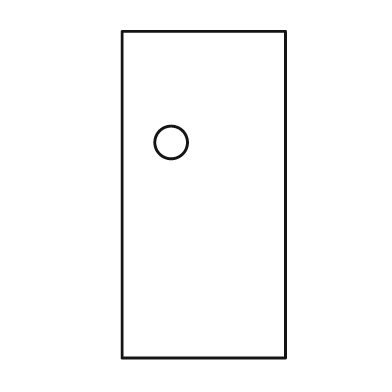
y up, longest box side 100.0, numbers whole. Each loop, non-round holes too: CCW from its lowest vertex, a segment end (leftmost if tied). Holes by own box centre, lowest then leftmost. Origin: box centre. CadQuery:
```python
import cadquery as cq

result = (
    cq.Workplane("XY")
    .moveTo(-25.0, -50.0)
    .lineTo(25.0, -50.0)
    .lineTo(25.0, 50.0)
    .lineTo(-25.0, 50.0)
    .close()
    .moveTo(-10.0, 16.0)
    .circle(5.0)
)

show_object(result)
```